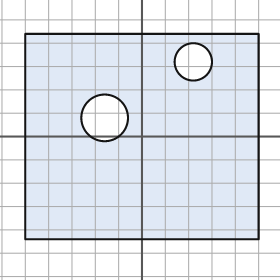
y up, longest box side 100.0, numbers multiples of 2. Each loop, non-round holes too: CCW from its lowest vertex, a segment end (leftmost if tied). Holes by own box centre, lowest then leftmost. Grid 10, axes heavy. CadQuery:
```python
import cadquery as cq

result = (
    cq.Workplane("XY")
    .moveTo(-50.0, -44.0)
    .lineTo(50.0, -44.0)
    .lineTo(50.0, 44.0)
    .lineTo(-50.0, 44.0)
    .close()
    .moveTo(-16.0, 8.0)
    .circle(10.0)
    .moveTo(22.0, 32.0)
    .circle(8.0)
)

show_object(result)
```